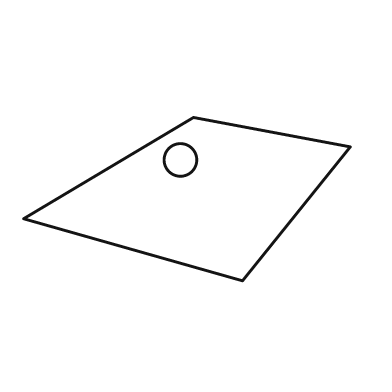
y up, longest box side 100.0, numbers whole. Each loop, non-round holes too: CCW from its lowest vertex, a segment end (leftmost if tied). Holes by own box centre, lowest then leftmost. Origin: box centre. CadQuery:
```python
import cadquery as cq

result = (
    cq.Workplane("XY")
    .moveTo(17.0, -25.0)
    .lineTo(50.0, 16.0)
    .lineTo(2.0, 25.0)
    .lineTo(-50.0, -6.0)
    .close()
    .moveTo(-2.0, 12.0)
    .circle(5.0)
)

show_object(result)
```